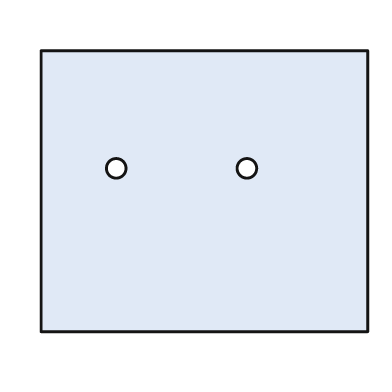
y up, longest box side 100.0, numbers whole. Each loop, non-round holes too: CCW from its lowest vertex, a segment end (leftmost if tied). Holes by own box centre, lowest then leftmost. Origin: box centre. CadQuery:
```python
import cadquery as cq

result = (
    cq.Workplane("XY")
    .moveTo(-50.0, -43.0)
    .lineTo(50.0, -43.0)
    .lineTo(50.0, 43.0)
    .lineTo(-50.0, 43.0)
    .close()
    .moveTo(-27.0, 7.0)
    .circle(3.0)
    .moveTo(13.0, 7.0)
    .circle(3.0)
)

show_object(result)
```